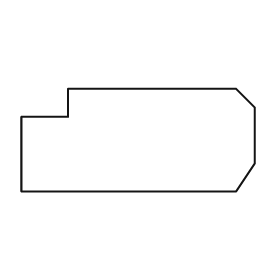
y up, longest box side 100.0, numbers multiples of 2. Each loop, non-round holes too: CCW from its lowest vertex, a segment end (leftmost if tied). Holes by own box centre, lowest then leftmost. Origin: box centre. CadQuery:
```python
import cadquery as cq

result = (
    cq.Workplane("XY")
    .moveTo(-50.0, -22.0)
    .lineTo(42.0, -22.0)
    .lineTo(50.0, -10.0)
    .lineTo(50.0, 14.0)
    .lineTo(42.0, 22.0)
    .lineTo(-30.0, 22.0)
    .lineTo(-30.0, 10.0)
    .lineTo(-50.0, 10.0)
    .close()
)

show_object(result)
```